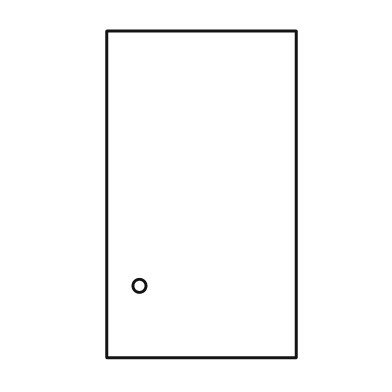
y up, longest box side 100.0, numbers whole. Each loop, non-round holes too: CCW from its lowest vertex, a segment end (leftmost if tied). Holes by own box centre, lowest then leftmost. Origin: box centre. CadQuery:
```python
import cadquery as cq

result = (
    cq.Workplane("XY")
    .moveTo(-29.0, -50.0)
    .lineTo(29.0, -50.0)
    .lineTo(29.0, 50.0)
    .lineTo(-29.0, 50.0)
    .close()
    .moveTo(-19.0, -28.0)
    .circle(2.0)
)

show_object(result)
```